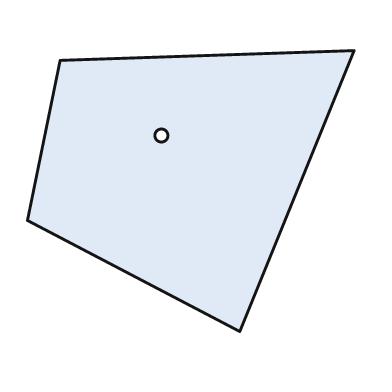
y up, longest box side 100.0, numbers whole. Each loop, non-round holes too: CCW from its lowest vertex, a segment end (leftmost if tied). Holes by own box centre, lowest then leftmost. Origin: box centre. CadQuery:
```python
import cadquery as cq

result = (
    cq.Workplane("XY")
    .moveTo(15.0, -43.0)
    .lineTo(50.0, 43.0)
    .lineTo(-40.0, 40.0)
    .lineTo(-50.0, -9.0)
    .close()
    .moveTo(-9.0, 17.0)
    .circle(2.0)
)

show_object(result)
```